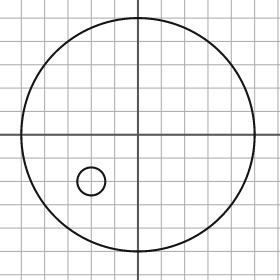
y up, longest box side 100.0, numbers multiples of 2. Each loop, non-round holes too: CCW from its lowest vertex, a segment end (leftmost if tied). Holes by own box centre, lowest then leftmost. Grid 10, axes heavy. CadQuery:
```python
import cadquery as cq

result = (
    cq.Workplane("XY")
    .moveTo(0.0, 0.0)
    .circle(50.0)
    .moveTo(-20.0, -20.0)
    .circle(6.0)
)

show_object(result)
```